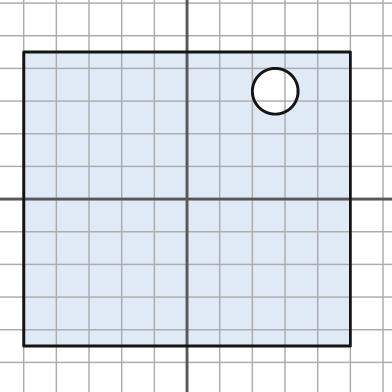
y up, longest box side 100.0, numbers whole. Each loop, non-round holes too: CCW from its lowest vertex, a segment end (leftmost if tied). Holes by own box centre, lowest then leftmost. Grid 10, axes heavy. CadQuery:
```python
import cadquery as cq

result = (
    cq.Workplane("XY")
    .moveTo(-50.0, -45.0)
    .lineTo(50.0, -45.0)
    .lineTo(50.0, 45.0)
    .lineTo(-50.0, 45.0)
    .close()
    .moveTo(27.0, 33.0)
    .circle(7.0)
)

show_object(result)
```